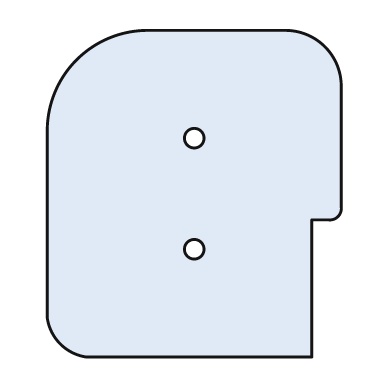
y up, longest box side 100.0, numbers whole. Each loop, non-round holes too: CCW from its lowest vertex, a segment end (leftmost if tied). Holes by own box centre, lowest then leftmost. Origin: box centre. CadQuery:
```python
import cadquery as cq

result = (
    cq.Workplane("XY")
    .moveTo(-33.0, -50.0)
    .lineTo(36.0, -50.0)
    .lineTo(36.0, -8.0)
    .lineTo(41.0, -8.0)
    .threePointArc((44.0, -7.0), (45.0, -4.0))
    .lineTo(45.0, 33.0)
    .threePointArc((40.0, 45.0), (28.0, 50.0))
    .lineTo(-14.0, 50.0)
    .threePointArc((-36.0, 41.0), (-45.0, 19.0))
    .lineTo(-45.0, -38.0)
    .threePointArc((-41.0, -46.0), (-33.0, -50.0))
    .close()
    .moveTo(0.0, -17.0)
    .circle(3.0)
    .moveTo(0.0, 17.0)
    .circle(3.0)
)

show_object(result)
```